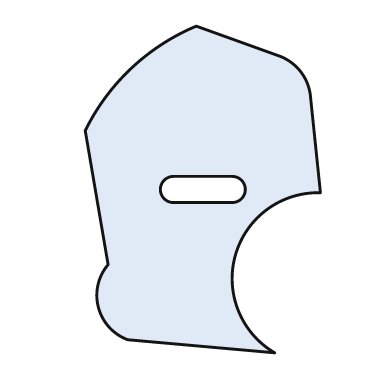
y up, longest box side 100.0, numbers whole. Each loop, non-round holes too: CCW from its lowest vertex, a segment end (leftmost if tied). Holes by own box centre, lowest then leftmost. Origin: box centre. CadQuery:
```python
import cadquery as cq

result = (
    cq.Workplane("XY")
    .moveTo(22.0, -50.0)
    .threePointArc((10.0, -20.0), (36.0, -1.0))
    .lineTo(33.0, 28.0)
    .threePointArc((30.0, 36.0), (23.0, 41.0))
    .lineTo(-2.0, 50.0)
    .threePointArc((-22.0, 37.0), (-36.0, 18.0))
    .lineTo(-29.0, -23.0)
    .threePointArc((-32.0, -36.0), (-23.0, -46.0))
    .close()
    .moveTo(-9.0, -4.0)
    .lineTo(9.0, -4.0)
    .threePointArc((13.0, 0.0), (9.0, 4.0))
    .lineTo(-9.0, 4.0)
    .threePointArc((-13.0, 0.0), (-9.0, -4.0))
    .close()
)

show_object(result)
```